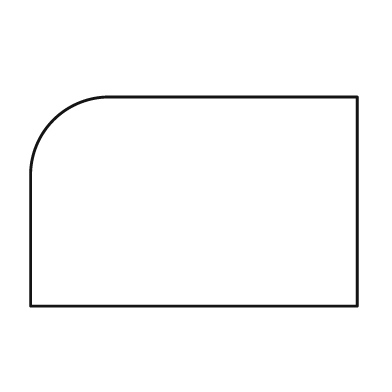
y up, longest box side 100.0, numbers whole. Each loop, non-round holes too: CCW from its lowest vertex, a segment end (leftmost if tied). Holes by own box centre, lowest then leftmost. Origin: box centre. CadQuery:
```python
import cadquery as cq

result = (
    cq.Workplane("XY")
    .moveTo(-50.0, -32.0)
    .lineTo(50.0, -32.0)
    .lineTo(50.0, 32.0)
    .lineTo(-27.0, 32.0)
    .threePointArc((-43.0, 25.0), (-50.0, 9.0))
    .close()
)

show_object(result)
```